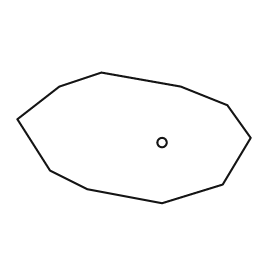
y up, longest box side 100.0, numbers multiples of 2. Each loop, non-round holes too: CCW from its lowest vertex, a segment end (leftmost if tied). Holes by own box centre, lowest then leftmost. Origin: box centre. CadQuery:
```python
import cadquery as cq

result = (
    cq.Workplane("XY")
    .moveTo(12.0, -28.0)
    .lineTo(38.0, -20.0)
    .lineTo(50.0, 0.0)
    .lineTo(40.0, 14.0)
    .lineTo(20.0, 22.0)
    .lineTo(-14.0, 28.0)
    .lineTo(-32.0, 22.0)
    .lineTo(-50.0, 8.0)
    .lineTo(-36.0, -14.0)
    .lineTo(-20.0, -22.0)
    .close()
    .moveTo(12.0, -2.0)
    .circle(2.0)
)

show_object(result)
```